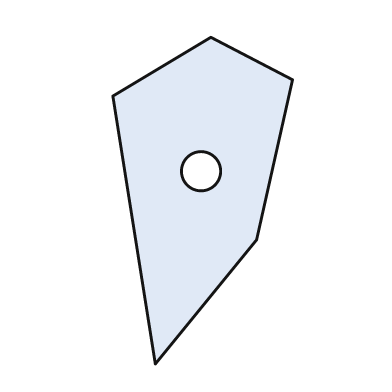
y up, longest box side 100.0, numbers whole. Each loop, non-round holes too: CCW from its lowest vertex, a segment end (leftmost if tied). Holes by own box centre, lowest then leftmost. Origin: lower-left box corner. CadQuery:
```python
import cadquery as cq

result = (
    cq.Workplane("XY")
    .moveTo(13.0, 0.0)
    .lineTo(44.0, 38.0)
    .lineTo(55.0, 87.0)
    .lineTo(30.0, 100.0)
    .lineTo(0.0, 82.0)
    .close()
    .moveTo(27.0, 59.0)
    .circle(6.0)
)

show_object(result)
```